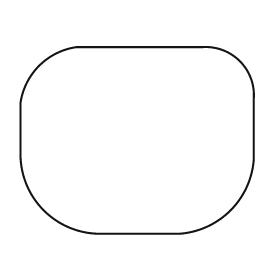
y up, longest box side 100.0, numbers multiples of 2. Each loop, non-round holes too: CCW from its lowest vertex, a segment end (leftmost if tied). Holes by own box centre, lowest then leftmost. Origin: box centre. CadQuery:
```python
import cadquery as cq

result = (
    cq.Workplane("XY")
    .moveTo(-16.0, -40.0)
    .lineTo(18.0, -40.0)
    .threePointArc((40.0, -30.0), (50.0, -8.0))
    .lineTo(50.0, 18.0)
    .threePointArc((44.0, 34.0), (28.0, 40.0))
    .lineTo(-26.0, 40.0)
    .threePointArc((-42.0, 32.0), (-50.0, 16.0))
    .lineTo(-50.0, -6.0)
    .threePointArc((-40.0, -30.0), (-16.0, -40.0))
    .close()
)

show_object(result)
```